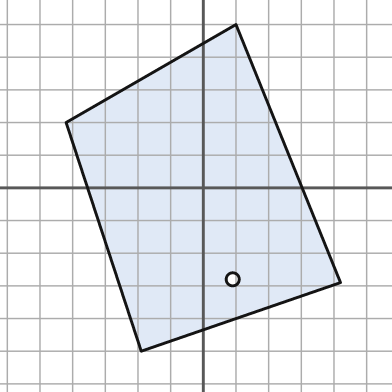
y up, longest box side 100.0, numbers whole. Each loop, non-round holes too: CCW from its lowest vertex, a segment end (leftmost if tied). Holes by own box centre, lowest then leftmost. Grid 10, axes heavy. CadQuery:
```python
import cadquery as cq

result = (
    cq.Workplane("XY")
    .moveTo(-19.0, -50.0)
    .lineTo(42.0, -29.0)
    .lineTo(10.0, 50.0)
    .lineTo(-42.0, 20.0)
    .close()
    .moveTo(9.0, -28.0)
    .circle(2.0)
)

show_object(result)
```